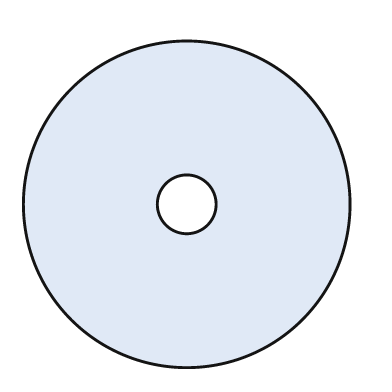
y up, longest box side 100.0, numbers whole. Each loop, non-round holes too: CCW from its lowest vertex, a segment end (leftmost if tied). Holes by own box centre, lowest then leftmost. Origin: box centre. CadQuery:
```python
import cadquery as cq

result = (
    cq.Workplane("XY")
    .moveTo(0.0, 0.0)
    .circle(50.0)
    .moveTo(0.0, 0.0)
    .circle(9.0)
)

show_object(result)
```